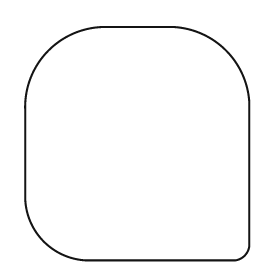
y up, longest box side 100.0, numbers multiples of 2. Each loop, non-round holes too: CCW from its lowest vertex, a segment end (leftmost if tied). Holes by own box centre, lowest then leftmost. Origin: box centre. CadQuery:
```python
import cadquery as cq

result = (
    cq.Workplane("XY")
    .moveTo(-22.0, -50.0)
    .lineTo(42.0, -50.0)
    .threePointArc((46.0, -48.0), (48.0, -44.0))
    .lineTo(48.0, 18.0)
    .threePointArc((38.0, 40.0), (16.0, 50.0))
    .lineTo(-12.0, 50.0)
    .threePointArc((-38.0, 40.0), (-48.0, 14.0))
    .lineTo(-48.0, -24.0)
    .threePointArc((-40.0, -42.0), (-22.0, -50.0))
    .close()
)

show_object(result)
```